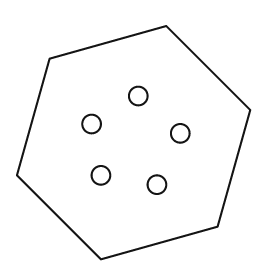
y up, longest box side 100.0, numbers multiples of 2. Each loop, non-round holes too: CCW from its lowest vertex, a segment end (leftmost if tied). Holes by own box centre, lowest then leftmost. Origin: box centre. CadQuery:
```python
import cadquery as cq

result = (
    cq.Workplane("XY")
    .moveTo(-14.0, -50.0)
    .lineTo(36.0, -36.0)
    .lineTo(50.0, 14.0)
    .lineTo(14.0, 50.0)
    .lineTo(-36.0, 36.0)
    .lineTo(-50.0, -14.0)
    .close()
    .moveTo(10.0, -18.0)
    .circle(4.0)
    .moveTo(-14.0, -14.0)
    .circle(4.0)
    .moveTo(20.0, 4.0)
    .circle(4.0)
    .moveTo(-18.0, 8.0)
    .circle(4.0)
    .moveTo(2.0, 20.0)
    .circle(4.0)
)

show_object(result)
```